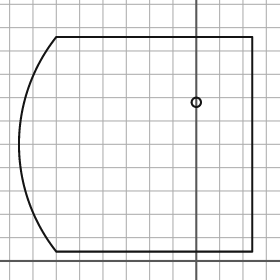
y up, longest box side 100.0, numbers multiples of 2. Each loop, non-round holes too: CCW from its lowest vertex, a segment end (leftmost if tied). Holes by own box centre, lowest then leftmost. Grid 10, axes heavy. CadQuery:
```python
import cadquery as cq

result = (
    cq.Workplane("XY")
    .moveTo(-60.0, 4.0)
    .lineTo(24.0, 4.0)
    .lineTo(24.0, 96.0)
    .lineTo(-60.0, 96.0)
    .threePointArc((-76.0, 50.0), (-60.0, 4.0))
    .close()
    .moveTo(0.0, 68.0)
    .circle(2.0)
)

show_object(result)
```